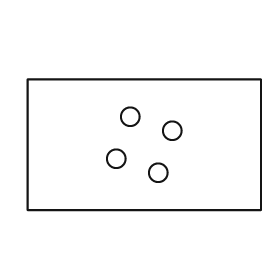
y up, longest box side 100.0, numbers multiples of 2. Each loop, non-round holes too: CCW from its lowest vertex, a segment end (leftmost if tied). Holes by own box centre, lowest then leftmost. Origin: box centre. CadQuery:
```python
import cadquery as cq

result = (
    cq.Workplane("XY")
    .moveTo(-50.0, -28.0)
    .lineTo(50.0, -28.0)
    .lineTo(50.0, 28.0)
    .lineTo(-50.0, 28.0)
    .close()
    .moveTo(6.0, -12.0)
    .circle(4.0)
    .moveTo(-12.0, -6.0)
    .circle(4.0)
    .moveTo(12.0, 6.0)
    .circle(4.0)
    .moveTo(-6.0, 12.0)
    .circle(4.0)
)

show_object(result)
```